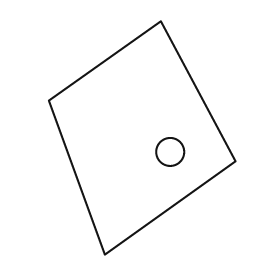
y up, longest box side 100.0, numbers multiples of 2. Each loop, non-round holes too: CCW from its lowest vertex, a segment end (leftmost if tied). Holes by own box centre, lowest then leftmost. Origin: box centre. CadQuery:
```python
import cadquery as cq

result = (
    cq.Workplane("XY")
    .moveTo(-16.0, -50.0)
    .lineTo(40.0, -10.0)
    .lineTo(8.0, 50.0)
    .lineTo(-40.0, 16.0)
    .close()
    .moveTo(12.0, -6.0)
    .circle(6.0)
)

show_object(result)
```